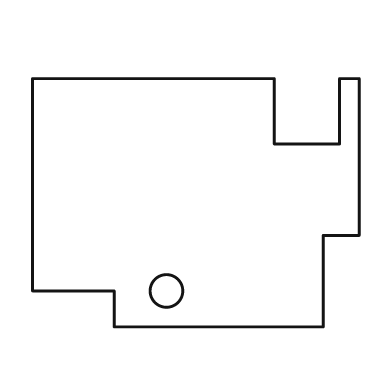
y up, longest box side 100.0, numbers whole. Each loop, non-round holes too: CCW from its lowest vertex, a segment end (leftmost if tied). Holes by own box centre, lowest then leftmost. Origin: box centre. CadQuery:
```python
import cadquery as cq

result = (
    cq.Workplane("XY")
    .moveTo(-25.0, -38.0)
    .lineTo(39.0, -38.0)
    .lineTo(39.0, -10.0)
    .lineTo(50.0, -10.0)
    .lineTo(50.0, 38.0)
    .lineTo(44.0, 38.0)
    .lineTo(44.0, 18.0)
    .lineTo(24.0, 18.0)
    .lineTo(24.0, 38.0)
    .lineTo(-50.0, 38.0)
    .lineTo(-50.0, -27.0)
    .lineTo(-25.0, -27.0)
    .close()
    .moveTo(-9.0, -27.0)
    .circle(5.0)
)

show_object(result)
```